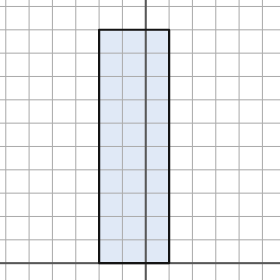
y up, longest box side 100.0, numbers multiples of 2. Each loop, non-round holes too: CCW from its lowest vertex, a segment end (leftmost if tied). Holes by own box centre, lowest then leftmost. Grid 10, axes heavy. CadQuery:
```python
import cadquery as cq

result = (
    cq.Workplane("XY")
    .moveTo(-20.0, 0.0)
    .lineTo(10.0, 0.0)
    .lineTo(10.0, 100.0)
    .lineTo(-20.0, 100.0)
    .close()
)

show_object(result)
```